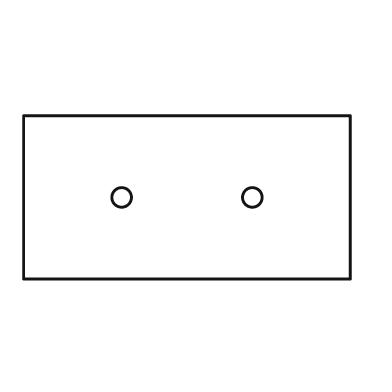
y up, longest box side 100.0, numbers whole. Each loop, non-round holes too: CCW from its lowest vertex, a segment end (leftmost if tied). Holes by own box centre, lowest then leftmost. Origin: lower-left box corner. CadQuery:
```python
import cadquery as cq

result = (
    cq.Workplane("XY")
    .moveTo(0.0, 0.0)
    .lineTo(100.0, 0.0)
    .lineTo(100.0, 50.0)
    .lineTo(0.0, 50.0)
    .close()
    .moveTo(30.0, 25.0)
    .circle(3.0)
    .moveTo(70.0, 25.0)
    .circle(3.0)
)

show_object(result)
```